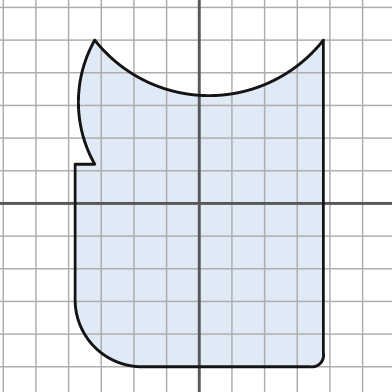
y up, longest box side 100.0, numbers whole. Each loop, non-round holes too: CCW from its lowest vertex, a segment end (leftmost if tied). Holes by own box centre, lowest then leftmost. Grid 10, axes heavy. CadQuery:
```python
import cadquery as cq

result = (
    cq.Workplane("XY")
    .moveTo(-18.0, -50.0)
    .lineTo(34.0, -50.0)
    .threePointArc((37.0, -49.0), (38.0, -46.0))
    .lineTo(38.0, 50.0)
    .threePointArc((3.0, 33.0), (-32.0, 50.0))
    .threePointArc((-37.0, 31.0), (-32.0, 12.0))
    .lineTo(-38.0, 12.0)
    .lineTo(-38.0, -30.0)
    .threePointArc((-32.0, -44.0), (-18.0, -50.0))
    .close()
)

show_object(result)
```